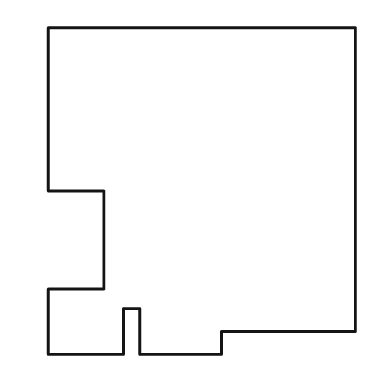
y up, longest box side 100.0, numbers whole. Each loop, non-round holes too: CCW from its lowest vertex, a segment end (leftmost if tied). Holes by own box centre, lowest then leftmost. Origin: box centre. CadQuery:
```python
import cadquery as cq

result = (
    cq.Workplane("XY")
    .moveTo(-47.0, -50.0)
    .lineTo(-24.0, -50.0)
    .lineTo(-24.0, -36.0)
    .lineTo(-19.0, -36.0)
    .lineTo(-19.0, -50.0)
    .lineTo(6.0, -50.0)
    .lineTo(6.0, -43.0)
    .lineTo(47.0, -43.0)
    .lineTo(47.0, 50.0)
    .lineTo(-47.0, 50.0)
    .lineTo(-47.0, 0.0)
    .lineTo(-30.0, 0.0)
    .lineTo(-30.0, -30.0)
    .lineTo(-47.0, -30.0)
    .close()
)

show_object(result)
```